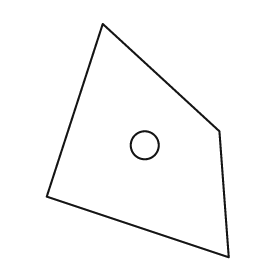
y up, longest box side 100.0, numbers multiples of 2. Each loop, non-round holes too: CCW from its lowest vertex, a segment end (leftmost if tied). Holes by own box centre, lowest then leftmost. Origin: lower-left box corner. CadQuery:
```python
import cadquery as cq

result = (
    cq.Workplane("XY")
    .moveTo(78.0, 0.0)
    .lineTo(74.0, 54.0)
    .lineTo(24.0, 100.0)
    .lineTo(0.0, 26.0)
    .close()
    .moveTo(42.0, 48.0)
    .circle(6.0)
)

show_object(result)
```